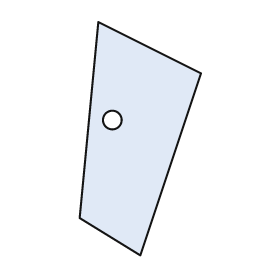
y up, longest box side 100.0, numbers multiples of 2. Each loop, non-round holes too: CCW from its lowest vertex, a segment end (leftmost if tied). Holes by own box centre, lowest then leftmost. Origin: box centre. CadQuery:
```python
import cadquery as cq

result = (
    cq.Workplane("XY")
    .moveTo(0.0, -50.0)
    .lineTo(26.0, 28.0)
    .lineTo(-18.0, 50.0)
    .lineTo(-26.0, -34.0)
    .close()
    .moveTo(-12.0, 8.0)
    .circle(4.0)
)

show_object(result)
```